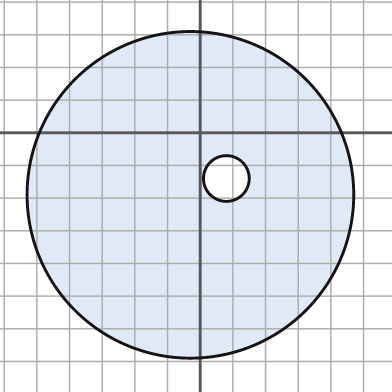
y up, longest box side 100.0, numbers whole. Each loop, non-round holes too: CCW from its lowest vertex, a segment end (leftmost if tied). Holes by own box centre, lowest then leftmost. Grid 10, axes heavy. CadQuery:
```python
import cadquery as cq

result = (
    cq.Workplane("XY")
    .moveTo(-3.0, -19.0)
    .circle(50.0)
    .moveTo(8.0, -14.0)
    .circle(7.0)
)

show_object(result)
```